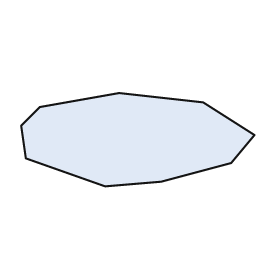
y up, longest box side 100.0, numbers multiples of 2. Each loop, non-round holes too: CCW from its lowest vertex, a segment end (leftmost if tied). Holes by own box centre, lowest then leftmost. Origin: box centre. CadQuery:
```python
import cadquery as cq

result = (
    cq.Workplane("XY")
    .moveTo(-14.0, -20.0)
    .lineTo(10.0, -18.0)
    .lineTo(40.0, -10.0)
    .lineTo(50.0, 2.0)
    .lineTo(28.0, 16.0)
    .lineTo(-8.0, 20.0)
    .lineTo(-42.0, 14.0)
    .lineTo(-50.0, 6.0)
    .lineTo(-48.0, -8.0)
    .close()
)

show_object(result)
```